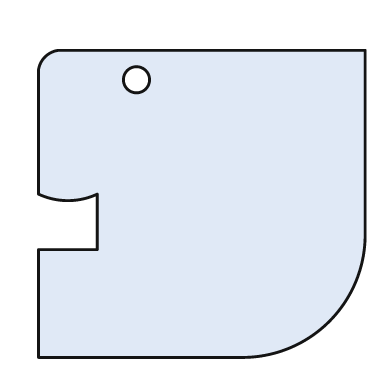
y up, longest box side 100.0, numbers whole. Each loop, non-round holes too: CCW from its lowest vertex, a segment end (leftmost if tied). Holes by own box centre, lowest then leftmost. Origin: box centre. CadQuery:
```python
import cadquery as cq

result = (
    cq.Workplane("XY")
    .moveTo(-50.0, -47.0)
    .lineTo(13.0, -47.0)
    .threePointArc((39.0, -36.0), (50.0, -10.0))
    .lineTo(50.0, 47.0)
    .lineTo(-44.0, 47.0)
    .threePointArc((-48.0, 45.0), (-50.0, 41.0))
    .lineTo(-50.0, 3.0)
    .threePointArc((-41.0, 1.0), (-32.0, 3.0))
    .lineTo(-32.0, -14.0)
    .lineTo(-50.0, -14.0)
    .close()
    .moveTo(-20.0, 38.0)
    .circle(4.0)
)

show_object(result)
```